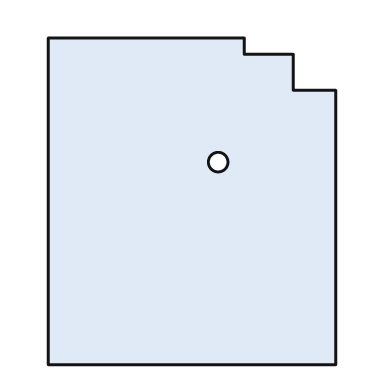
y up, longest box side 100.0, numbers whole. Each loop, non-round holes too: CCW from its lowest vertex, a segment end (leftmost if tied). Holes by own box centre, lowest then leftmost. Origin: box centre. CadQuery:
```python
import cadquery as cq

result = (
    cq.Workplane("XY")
    .moveTo(-44.0, -50.0)
    .lineTo(44.0, -50.0)
    .lineTo(44.0, 34.0)
    .lineTo(31.0, 34.0)
    .lineTo(31.0, 45.0)
    .lineTo(16.0, 45.0)
    .lineTo(16.0, 50.0)
    .lineTo(-44.0, 50.0)
    .close()
    .moveTo(8.0, 12.0)
    .circle(3.0)
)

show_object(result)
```